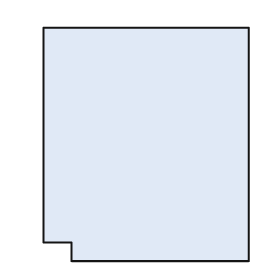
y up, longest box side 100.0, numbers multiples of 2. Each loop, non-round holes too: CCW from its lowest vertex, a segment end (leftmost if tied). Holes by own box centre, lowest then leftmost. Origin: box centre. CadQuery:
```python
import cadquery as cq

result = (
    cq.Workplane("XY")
    .moveTo(-32.0, -50.0)
    .lineTo(44.0, -50.0)
    .lineTo(44.0, 50.0)
    .lineTo(-44.0, 50.0)
    .lineTo(-44.0, -42.0)
    .lineTo(-32.0, -42.0)
    .close()
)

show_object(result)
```